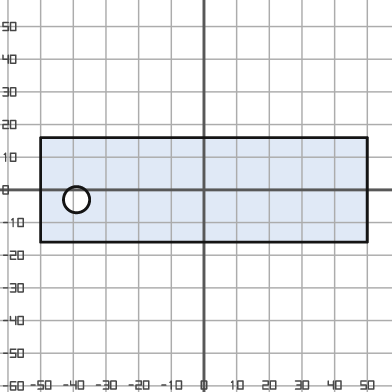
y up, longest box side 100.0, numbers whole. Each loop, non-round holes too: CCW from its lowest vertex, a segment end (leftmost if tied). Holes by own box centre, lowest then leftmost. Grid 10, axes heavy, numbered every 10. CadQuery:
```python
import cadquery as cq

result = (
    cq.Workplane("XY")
    .moveTo(-50.0, -16.0)
    .lineTo(50.0, -16.0)
    .lineTo(50.0, 16.0)
    .lineTo(-50.0, 16.0)
    .close()
    .moveTo(-39.0, -3.0)
    .circle(4.0)
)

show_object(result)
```